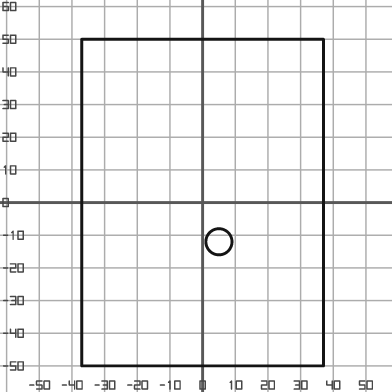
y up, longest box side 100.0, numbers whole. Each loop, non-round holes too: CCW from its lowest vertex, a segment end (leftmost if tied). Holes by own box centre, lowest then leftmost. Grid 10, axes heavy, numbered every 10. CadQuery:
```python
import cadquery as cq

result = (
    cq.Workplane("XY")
    .moveTo(-37.0, -50.0)
    .lineTo(37.0, -50.0)
    .lineTo(37.0, 50.0)
    .lineTo(-37.0, 50.0)
    .close()
    .moveTo(5.0, -12.0)
    .circle(4.0)
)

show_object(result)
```